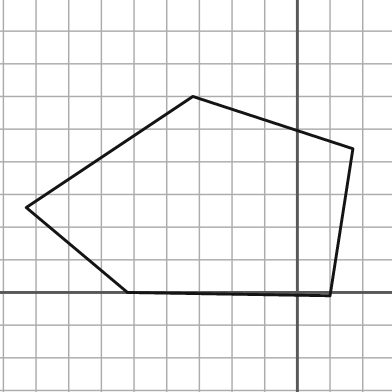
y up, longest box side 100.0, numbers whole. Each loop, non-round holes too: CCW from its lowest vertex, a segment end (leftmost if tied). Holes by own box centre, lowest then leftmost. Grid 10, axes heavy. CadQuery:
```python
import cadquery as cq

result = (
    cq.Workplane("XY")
    .moveTo(10.0, -1.0)
    .lineTo(17.0, 44.0)
    .lineTo(-32.0, 60.0)
    .lineTo(-83.0, 26.0)
    .lineTo(-52.0, 0.0)
    .close()
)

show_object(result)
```